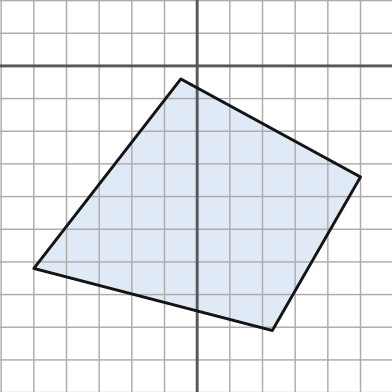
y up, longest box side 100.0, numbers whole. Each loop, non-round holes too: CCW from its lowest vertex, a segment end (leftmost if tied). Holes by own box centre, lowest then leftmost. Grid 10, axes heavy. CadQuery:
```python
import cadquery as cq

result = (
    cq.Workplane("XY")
    .moveTo(23.0, -81.0)
    .lineTo(50.0, -34.0)
    .lineTo(-5.0, -4.0)
    .lineTo(-50.0, -62.0)
    .close()
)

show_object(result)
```